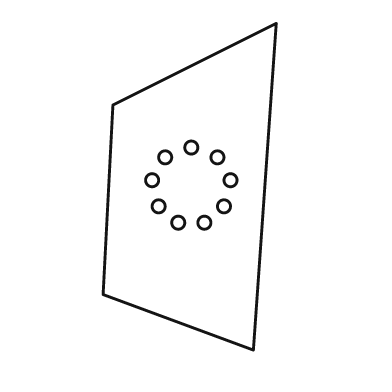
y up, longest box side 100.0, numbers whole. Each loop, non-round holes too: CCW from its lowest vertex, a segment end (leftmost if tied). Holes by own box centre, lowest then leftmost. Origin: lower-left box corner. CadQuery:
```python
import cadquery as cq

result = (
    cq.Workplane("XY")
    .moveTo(46.0, 0.0)
    .lineTo(53.0, 100.0)
    .lineTo(3.0, 75.0)
    .lineTo(0.0, 17.0)
    .close()
    .moveTo(23.0, 39.0)
    .circle(2.0)
    .moveTo(31.0, 39.0)
    .circle(2.0)
    .moveTo(17.0, 44.0)
    .circle(2.0)
    .moveTo(37.0, 44.0)
    .circle(2.0)
    .moveTo(15.0, 52.0)
    .circle(2.0)
    .moveTo(39.0, 52.0)
    .circle(2.0)
    .moveTo(19.0, 59.0)
    .circle(2.0)
    .moveTo(35.0, 59.0)
    .circle(2.0)
    .moveTo(27.0, 62.0)
    .circle(2.0)
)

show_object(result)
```